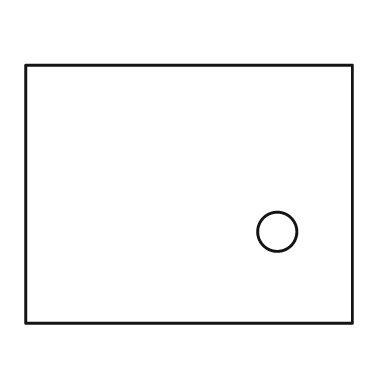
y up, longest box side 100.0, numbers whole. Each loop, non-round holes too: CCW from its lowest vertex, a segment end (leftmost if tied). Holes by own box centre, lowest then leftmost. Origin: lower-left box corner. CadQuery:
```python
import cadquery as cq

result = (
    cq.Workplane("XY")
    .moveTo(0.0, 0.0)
    .lineTo(100.0, 0.0)
    .lineTo(100.0, 79.0)
    .lineTo(0.0, 79.0)
    .close()
    .moveTo(77.0, 28.0)
    .circle(6.0)
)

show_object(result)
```